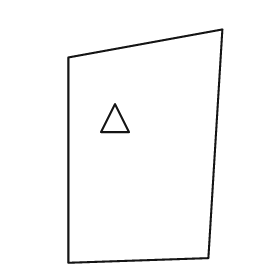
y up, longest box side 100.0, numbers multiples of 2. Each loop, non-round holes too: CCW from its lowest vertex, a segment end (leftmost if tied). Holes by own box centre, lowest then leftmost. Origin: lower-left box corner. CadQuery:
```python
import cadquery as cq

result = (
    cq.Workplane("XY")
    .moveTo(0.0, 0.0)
    .lineTo(60.0, 2.0)
    .lineTo(66.0, 100.0)
    .lineTo(0.0, 88.0)
    .close()
    .moveTo(14.0, 56.0)
    .lineTo(26.0, 56.0)
    .lineTo(20.0, 68.0)
    .close()
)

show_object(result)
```